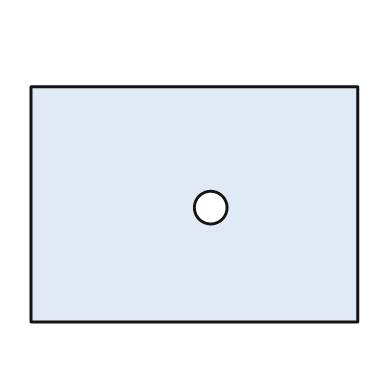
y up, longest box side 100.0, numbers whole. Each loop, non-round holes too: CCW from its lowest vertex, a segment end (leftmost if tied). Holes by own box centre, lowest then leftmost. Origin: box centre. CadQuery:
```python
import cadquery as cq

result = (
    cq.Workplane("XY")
    .moveTo(-50.0, -36.0)
    .lineTo(50.0, -36.0)
    .lineTo(50.0, 36.0)
    .lineTo(-50.0, 36.0)
    .close()
    .moveTo(5.0, -1.0)
    .circle(5.0)
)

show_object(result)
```